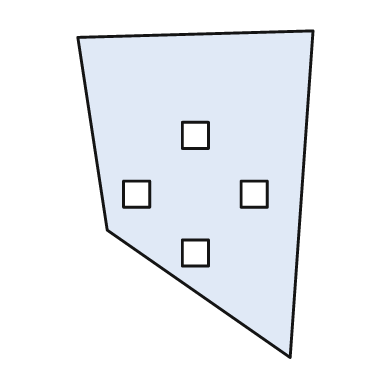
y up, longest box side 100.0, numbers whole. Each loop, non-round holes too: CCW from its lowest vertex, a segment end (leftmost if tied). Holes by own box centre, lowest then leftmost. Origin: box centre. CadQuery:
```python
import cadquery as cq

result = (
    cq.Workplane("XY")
    .moveTo(29.0, -50.0)
    .lineTo(36.0, 50.0)
    .lineTo(-36.0, 48.0)
    .lineTo(-27.0, -11.0)
    .close()
    .moveTo(-4.0, -22.0)
    .lineTo(4.0, -22.0)
    .lineTo(4.0, -14.0)
    .lineTo(-4.0, -14.0)
    .close()
    .moveTo(-22.0, -4.0)
    .lineTo(-14.0, -4.0)
    .lineTo(-14.0, 4.0)
    .lineTo(-22.0, 4.0)
    .close()
    .moveTo(14.0, -4.0)
    .lineTo(22.0, -4.0)
    .lineTo(22.0, 4.0)
    .lineTo(14.0, 4.0)
    .close()
    .moveTo(-4.0, 14.0)
    .lineTo(4.0, 14.0)
    .lineTo(4.0, 22.0)
    .lineTo(-4.0, 22.0)
    .close()
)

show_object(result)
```